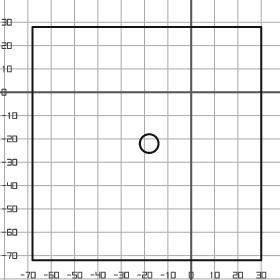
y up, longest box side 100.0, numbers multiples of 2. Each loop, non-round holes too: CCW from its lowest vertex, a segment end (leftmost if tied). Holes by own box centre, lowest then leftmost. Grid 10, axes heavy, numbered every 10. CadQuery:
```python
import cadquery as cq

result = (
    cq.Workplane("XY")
    .moveTo(-68.0, -72.0)
    .lineTo(30.0, -72.0)
    .lineTo(30.0, 28.0)
    .lineTo(-68.0, 28.0)
    .close()
    .moveTo(-18.0, -22.0)
    .circle(4.0)
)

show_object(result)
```